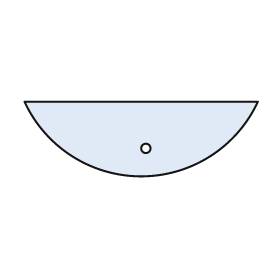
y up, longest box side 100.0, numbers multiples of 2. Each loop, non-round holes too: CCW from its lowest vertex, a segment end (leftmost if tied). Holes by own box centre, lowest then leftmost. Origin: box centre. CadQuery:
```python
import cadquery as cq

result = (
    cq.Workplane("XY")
    .moveTo(-50.0, 16.0)
    .threePointArc((0.0, -16.0), (50.0, 16.0))
    .close()
    .moveTo(2.0, -4.0)
    .circle(2.0)
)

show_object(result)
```